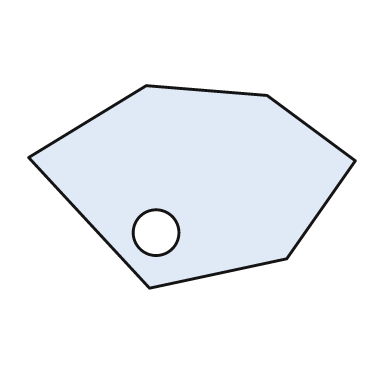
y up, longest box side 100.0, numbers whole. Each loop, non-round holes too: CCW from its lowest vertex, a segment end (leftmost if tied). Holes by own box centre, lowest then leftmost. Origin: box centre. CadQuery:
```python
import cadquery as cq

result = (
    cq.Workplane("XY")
    .moveTo(-13.0, -31.0)
    .lineTo(29.0, -22.0)
    .lineTo(50.0, 8.0)
    .lineTo(23.0, 28.0)
    .lineTo(-14.0, 31.0)
    .lineTo(-50.0, 9.0)
    .close()
    .moveTo(-11.0, -14.0)
    .circle(7.0)
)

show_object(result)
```